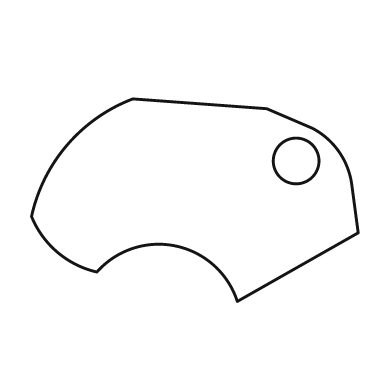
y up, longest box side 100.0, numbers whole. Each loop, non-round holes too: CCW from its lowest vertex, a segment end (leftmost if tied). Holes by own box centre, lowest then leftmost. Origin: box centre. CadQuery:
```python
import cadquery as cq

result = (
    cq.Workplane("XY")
    .moveTo(13.0, -31.0)
    .lineTo(50.0, -10.0)
    .lineTo(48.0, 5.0)
    .threePointArc((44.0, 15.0), (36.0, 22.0))
    .lineTo(22.0, 28.0)
    .lineTo(-19.0, 31.0)
    .threePointArc((-39.0, 17.0), (-50.0, -5.0))
    .threePointArc((-42.0, -16.0), (-30.0, -22.0))
    .threePointArc((-6.0, -14.0), (13.0, -31.0))
    .close()
    .moveTo(31.0, 12.0)
    .circle(7.0)
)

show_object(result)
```